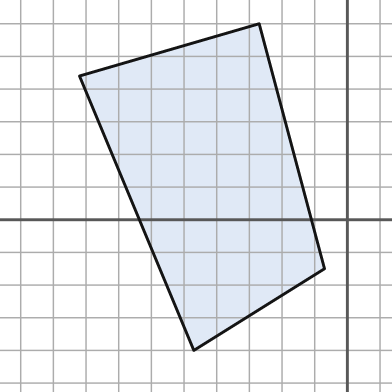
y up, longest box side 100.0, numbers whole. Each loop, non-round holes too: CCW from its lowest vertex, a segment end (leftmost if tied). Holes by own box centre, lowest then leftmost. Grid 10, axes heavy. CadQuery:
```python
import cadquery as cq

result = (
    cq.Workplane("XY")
    .moveTo(-47.0, -40.0)
    .lineTo(-7.0, -15.0)
    .lineTo(-27.0, 60.0)
    .lineTo(-82.0, 44.0)
    .close()
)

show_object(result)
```